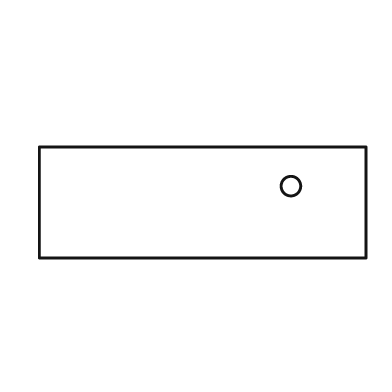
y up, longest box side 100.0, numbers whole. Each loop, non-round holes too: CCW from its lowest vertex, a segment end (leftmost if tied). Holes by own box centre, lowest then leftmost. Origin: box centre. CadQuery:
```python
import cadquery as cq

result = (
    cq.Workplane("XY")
    .moveTo(-50.0, -17.0)
    .lineTo(50.0, -17.0)
    .lineTo(50.0, 17.0)
    .lineTo(-50.0, 17.0)
    .close()
    .moveTo(27.0, 5.0)
    .circle(3.0)
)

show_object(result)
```